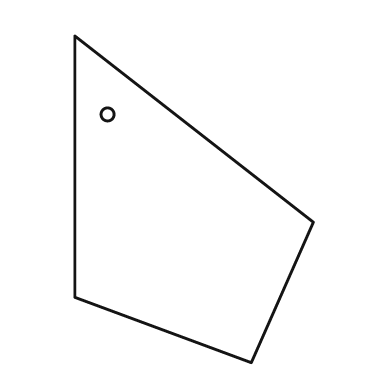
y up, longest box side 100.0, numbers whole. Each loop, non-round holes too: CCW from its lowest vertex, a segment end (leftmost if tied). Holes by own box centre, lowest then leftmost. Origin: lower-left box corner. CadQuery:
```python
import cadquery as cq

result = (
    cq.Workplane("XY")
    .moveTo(54.0, 0.0)
    .lineTo(73.0, 43.0)
    .lineTo(0.0, 100.0)
    .lineTo(0.0, 20.0)
    .close()
    .moveTo(10.0, 76.0)
    .circle(2.0)
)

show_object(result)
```